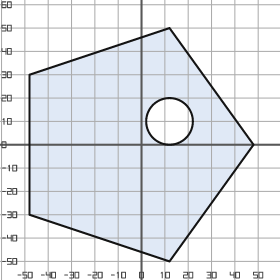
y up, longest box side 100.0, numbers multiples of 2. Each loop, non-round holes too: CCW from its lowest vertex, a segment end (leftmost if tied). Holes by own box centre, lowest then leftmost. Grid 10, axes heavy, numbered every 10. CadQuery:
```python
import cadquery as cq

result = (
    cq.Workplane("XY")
    .moveTo(12.0, -50.0)
    .lineTo(48.0, 0.0)
    .lineTo(12.0, 50.0)
    .lineTo(-48.0, 30.0)
    .lineTo(-48.0, -30.0)
    .close()
    .moveTo(12.0, 10.0)
    .circle(10.0)
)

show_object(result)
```